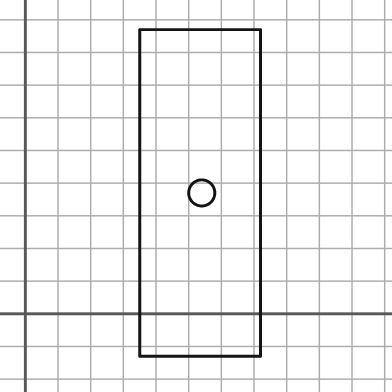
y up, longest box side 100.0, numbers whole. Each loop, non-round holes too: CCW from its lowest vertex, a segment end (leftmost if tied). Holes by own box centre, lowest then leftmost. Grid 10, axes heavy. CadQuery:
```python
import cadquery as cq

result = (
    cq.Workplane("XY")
    .moveTo(35.0, -13.0)
    .lineTo(72.0, -13.0)
    .lineTo(72.0, 87.0)
    .lineTo(35.0, 87.0)
    .close()
    .moveTo(54.0, 37.0)
    .circle(4.0)
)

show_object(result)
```